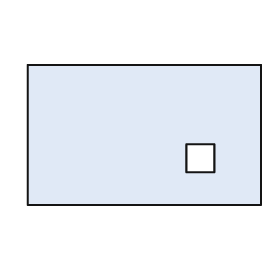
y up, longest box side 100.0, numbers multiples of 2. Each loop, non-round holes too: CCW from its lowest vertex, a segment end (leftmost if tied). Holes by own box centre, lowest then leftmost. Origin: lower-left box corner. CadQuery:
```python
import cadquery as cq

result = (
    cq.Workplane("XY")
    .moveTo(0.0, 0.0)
    .lineTo(100.0, 0.0)
    .lineTo(100.0, 60.0)
    .lineTo(0.0, 60.0)
    .close()
    .moveTo(68.0, 14.0)
    .lineTo(80.0, 14.0)
    .lineTo(80.0, 26.0)
    .lineTo(68.0, 26.0)
    .close()
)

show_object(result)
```